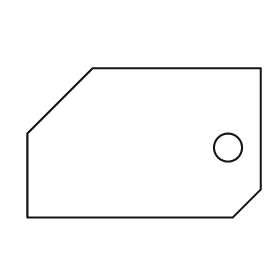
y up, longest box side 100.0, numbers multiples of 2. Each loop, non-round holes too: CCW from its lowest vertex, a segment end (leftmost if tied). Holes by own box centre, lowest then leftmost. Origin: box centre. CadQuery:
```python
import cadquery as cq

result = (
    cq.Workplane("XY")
    .moveTo(-50.0, -32.0)
    .lineTo(38.0, -32.0)
    .lineTo(50.0, -20.0)
    .lineTo(50.0, 32.0)
    .lineTo(-22.0, 32.0)
    .lineTo(-50.0, 4.0)
    .close()
    .moveTo(36.0, -2.0)
    .circle(6.0)
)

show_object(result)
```